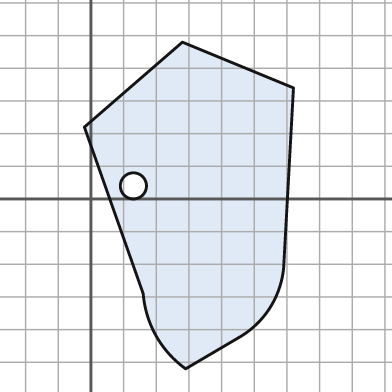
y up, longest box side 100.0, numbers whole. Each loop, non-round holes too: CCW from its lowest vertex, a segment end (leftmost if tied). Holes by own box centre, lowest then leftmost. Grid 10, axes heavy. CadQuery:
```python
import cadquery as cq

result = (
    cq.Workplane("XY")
    .moveTo(29.0, -52.0)
    .lineTo(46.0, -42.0)
    .threePointArc((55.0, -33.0), (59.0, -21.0))
    .lineTo(62.0, 34.0)
    .lineTo(28.0, 48.0)
    .lineTo(-2.0, 22.0)
    .lineTo(16.0, -29.0)
    .threePointArc((20.0, -42.0), (29.0, -52.0))
    .close()
    .moveTo(13.0, 4.0)
    .circle(4.0)
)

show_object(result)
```